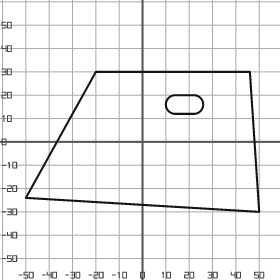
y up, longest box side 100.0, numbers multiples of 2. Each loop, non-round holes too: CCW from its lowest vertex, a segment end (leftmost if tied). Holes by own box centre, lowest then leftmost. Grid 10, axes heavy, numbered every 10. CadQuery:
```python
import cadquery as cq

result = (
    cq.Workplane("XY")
    .moveTo(50.0, -30.0)
    .lineTo(46.0, 30.0)
    .lineTo(-20.0, 30.0)
    .lineTo(-50.0, -24.0)
    .close()
    .moveTo(14.0, 12.0)
    .lineTo(22.0, 12.0)
    .threePointArc((26.0, 16.0), (22.0, 20.0))
    .lineTo(14.0, 20.0)
    .threePointArc((10.0, 16.0), (14.0, 12.0))
    .close()
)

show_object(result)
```